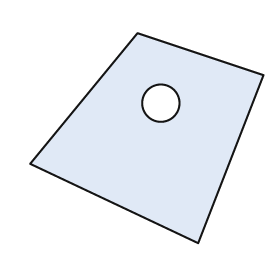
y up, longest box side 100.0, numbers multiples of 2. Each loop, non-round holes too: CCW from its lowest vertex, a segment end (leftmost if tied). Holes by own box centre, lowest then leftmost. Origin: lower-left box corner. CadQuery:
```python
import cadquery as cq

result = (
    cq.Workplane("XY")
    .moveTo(72.0, 0.0)
    .lineTo(100.0, 72.0)
    .lineTo(46.0, 90.0)
    .lineTo(0.0, 34.0)
    .close()
    .moveTo(56.0, 60.0)
    .circle(8.0)
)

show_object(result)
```